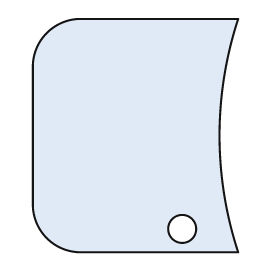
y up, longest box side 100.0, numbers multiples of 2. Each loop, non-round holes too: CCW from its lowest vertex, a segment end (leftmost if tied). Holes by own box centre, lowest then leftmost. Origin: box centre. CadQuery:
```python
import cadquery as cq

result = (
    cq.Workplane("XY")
    .moveTo(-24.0, -50.0)
    .lineTo(44.0, -50.0)
    .threePointArc((36.0, 0.0), (44.0, 50.0))
    .lineTo(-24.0, 50.0)
    .threePointArc((-38.0, 44.0), (-44.0, 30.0))
    .lineTo(-44.0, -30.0)
    .threePointArc((-38.0, -44.0), (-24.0, -50.0))
    .close()
    .moveTo(20.0, -40.0)
    .circle(6.0)
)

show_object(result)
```